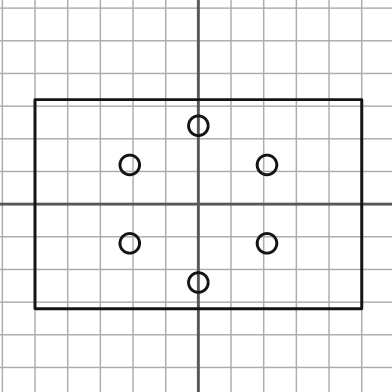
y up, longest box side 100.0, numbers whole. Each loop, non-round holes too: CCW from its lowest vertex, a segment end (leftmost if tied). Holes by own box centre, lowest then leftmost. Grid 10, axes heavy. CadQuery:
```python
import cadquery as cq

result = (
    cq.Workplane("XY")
    .moveTo(-50.0, -32.0)
    .lineTo(50.0, -32.0)
    .lineTo(50.0, 32.0)
    .lineTo(-50.0, 32.0)
    .close()
    .moveTo(0.0, -24.0)
    .circle(3.0)
    .moveTo(-21.0, -12.0)
    .circle(3.0)
    .moveTo(21.0, -12.0)
    .circle(3.0)
    .moveTo(-21.0, 12.0)
    .circle(3.0)
    .moveTo(21.0, 12.0)
    .circle(3.0)
    .moveTo(0.0, 24.0)
    .circle(3.0)
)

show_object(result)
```